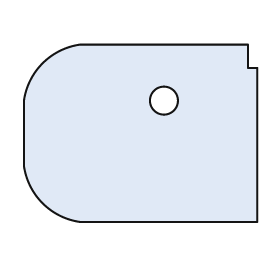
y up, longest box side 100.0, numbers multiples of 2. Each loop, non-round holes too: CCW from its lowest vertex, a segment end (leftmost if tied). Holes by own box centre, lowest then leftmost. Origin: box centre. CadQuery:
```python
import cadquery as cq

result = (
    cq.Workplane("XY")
    .moveTo(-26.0, -38.0)
    .lineTo(50.0, -38.0)
    .lineTo(50.0, 28.0)
    .lineTo(46.0, 28.0)
    .lineTo(46.0, 38.0)
    .lineTo(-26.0, 38.0)
    .threePointArc((-42.0, 30.0), (-50.0, 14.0))
    .lineTo(-50.0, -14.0)
    .threePointArc((-42.0, -30.0), (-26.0, -38.0))
    .close()
    .moveTo(10.0, 14.0)
    .circle(6.0)
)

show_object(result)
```